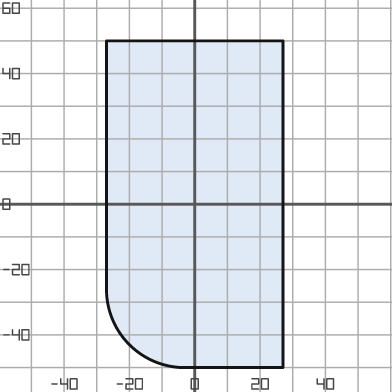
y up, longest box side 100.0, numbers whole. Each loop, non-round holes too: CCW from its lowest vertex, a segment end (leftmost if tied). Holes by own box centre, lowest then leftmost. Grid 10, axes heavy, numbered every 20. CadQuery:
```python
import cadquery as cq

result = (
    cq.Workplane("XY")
    .moveTo(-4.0, -50.0)
    .lineTo(27.0, -50.0)
    .lineTo(27.0, 50.0)
    .lineTo(-27.0, 50.0)
    .lineTo(-27.0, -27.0)
    .threePointArc((-20.0, -43.0), (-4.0, -50.0))
    .close()
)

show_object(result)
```